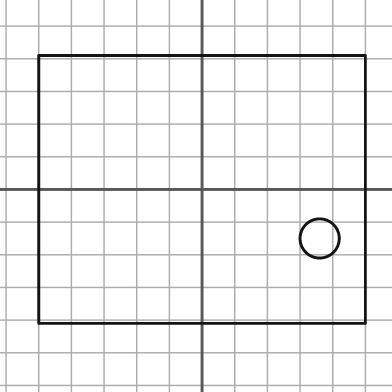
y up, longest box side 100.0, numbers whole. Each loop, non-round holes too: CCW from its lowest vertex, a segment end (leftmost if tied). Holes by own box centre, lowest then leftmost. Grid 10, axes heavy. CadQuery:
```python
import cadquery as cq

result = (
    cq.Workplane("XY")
    .moveTo(-50.0, -41.0)
    .lineTo(50.0, -41.0)
    .lineTo(50.0, 41.0)
    .lineTo(-50.0, 41.0)
    .close()
    .moveTo(36.0, -15.0)
    .circle(6.0)
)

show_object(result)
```